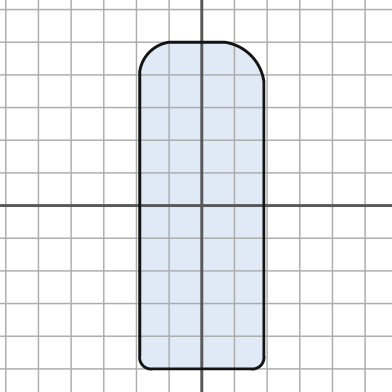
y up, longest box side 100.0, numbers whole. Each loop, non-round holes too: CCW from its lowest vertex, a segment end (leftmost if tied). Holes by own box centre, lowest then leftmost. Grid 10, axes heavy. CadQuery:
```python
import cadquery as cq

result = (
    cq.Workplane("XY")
    .moveTo(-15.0, -50.0)
    .lineTo(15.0, -50.0)
    .threePointArc((18.0, -49.0), (19.0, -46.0))
    .lineTo(19.0, 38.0)
    .threePointArc((15.0, 46.0), (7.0, 50.0))
    .lineTo(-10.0, 50.0)
    .threePointArc((-16.0, 47.0), (-19.0, 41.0))
    .lineTo(-19.0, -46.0)
    .threePointArc((-18.0, -49.0), (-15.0, -50.0))
    .close()
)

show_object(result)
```